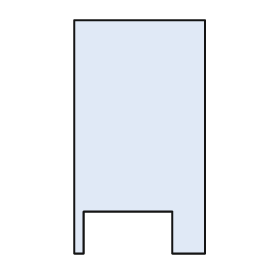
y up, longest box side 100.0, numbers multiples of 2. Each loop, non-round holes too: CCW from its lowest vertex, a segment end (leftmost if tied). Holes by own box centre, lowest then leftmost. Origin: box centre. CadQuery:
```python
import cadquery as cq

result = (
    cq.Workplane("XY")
    .moveTo(-28.0, -50.0)
    .lineTo(-24.0, -50.0)
    .lineTo(-24.0, -32.0)
    .lineTo(14.0, -32.0)
    .lineTo(14.0, -50.0)
    .lineTo(28.0, -50.0)
    .lineTo(28.0, 50.0)
    .lineTo(-28.0, 50.0)
    .close()
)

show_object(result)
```